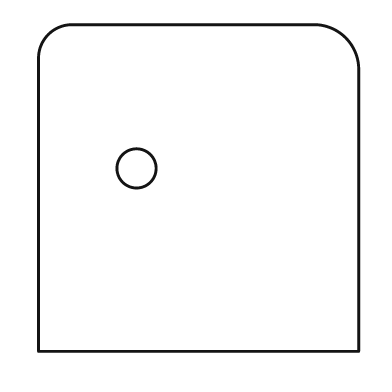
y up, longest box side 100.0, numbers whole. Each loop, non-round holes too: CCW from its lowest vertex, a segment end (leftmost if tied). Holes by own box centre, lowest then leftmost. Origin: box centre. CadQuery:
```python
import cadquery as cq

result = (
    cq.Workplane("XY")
    .moveTo(-49.0, -50.0)
    .lineTo(49.0, -50.0)
    .lineTo(49.0, 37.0)
    .threePointArc((45.0, 46.0), (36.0, 50.0))
    .lineTo(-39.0, 50.0)
    .threePointArc((-46.0, 47.0), (-49.0, 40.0))
    .close()
    .moveTo(-19.0, 6.0)
    .circle(6.0)
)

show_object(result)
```